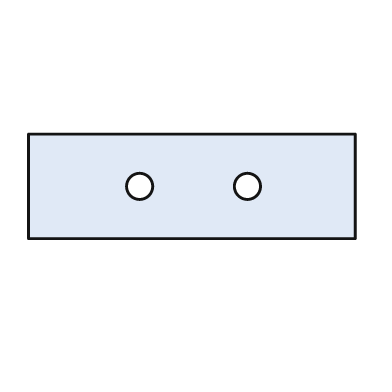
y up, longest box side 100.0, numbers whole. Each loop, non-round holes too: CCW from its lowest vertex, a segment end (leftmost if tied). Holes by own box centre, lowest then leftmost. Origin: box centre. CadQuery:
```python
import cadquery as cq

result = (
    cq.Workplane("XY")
    .moveTo(-50.0, -16.0)
    .lineTo(50.0, -16.0)
    .lineTo(50.0, 16.0)
    .lineTo(-50.0, 16.0)
    .close()
    .moveTo(-16.0, 0.0)
    .circle(4.0)
    .moveTo(17.0, 0.0)
    .circle(4.0)
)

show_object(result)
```